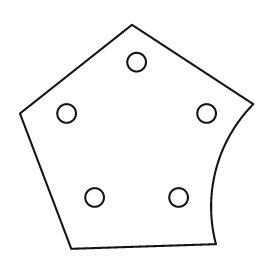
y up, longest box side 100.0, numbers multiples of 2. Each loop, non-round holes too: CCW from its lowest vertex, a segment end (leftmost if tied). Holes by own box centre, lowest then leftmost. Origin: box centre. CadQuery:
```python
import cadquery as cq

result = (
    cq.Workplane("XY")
    .moveTo(-28.0, -48.0)
    .lineTo(34.0, -46.0)
    .threePointArc((34.0, -14.0), (50.0, 14.0))
    .lineTo(-2.0, 48.0)
    .lineTo(-50.0, 10.0)
    .close()
    .moveTo(-18.0, -26.0)
    .circle(4.0)
    .moveTo(18.0, -26.0)
    .circle(4.0)
    .moveTo(-30.0, 10.0)
    .circle(4.0)
    .moveTo(30.0, 10.0)
    .circle(4.0)
    .moveTo(0.0, 32.0)
    .circle(4.0)
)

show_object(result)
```